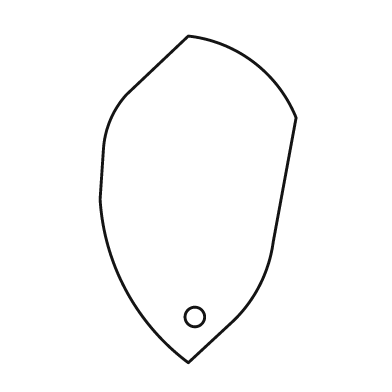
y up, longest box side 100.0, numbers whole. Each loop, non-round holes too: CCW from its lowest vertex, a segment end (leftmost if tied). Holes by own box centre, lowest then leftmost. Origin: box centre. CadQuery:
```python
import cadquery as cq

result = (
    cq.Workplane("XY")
    .moveTo(-3.0, -50.0)
    .lineTo(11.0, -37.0)
    .threePointArc((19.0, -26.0), (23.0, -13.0))
    .lineTo(30.0, 25.0)
    .threePointArc((17.0, 42.0), (-3.0, 50.0))
    .lineTo(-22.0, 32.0)
    .threePointArc((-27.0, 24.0), (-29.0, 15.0))
    .lineTo(-30.0, 0.0)
    .threePointArc((-22.0, -28.0), (-3.0, -50.0))
    .close()
    .moveTo(-1.0, -36.0)
    .circle(3.0)
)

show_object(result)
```